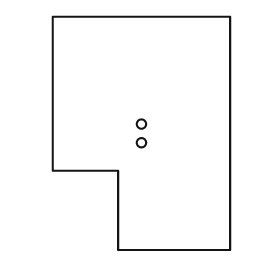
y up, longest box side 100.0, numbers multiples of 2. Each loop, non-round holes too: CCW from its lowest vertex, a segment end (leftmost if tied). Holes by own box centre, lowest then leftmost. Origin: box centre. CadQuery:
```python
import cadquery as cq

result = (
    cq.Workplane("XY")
    .moveTo(-10.0, -50.0)
    .lineTo(38.0, -50.0)
    .lineTo(38.0, 50.0)
    .lineTo(-38.0, 50.0)
    .lineTo(-38.0, -16.0)
    .lineTo(-10.0, -16.0)
    .close()
    .moveTo(0.0, -4.0)
    .circle(2.0)
    .moveTo(0.0, 4.0)
    .circle(2.0)
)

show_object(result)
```